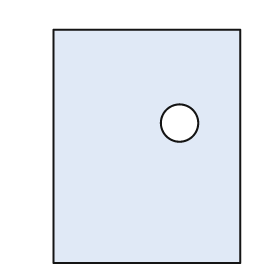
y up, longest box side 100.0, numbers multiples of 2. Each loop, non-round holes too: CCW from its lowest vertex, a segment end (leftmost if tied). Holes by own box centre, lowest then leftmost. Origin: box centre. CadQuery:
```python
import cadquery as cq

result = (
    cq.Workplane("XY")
    .moveTo(-40.0, -50.0)
    .lineTo(40.0, -50.0)
    .lineTo(40.0, 50.0)
    .lineTo(-40.0, 50.0)
    .close()
    .moveTo(14.0, 10.0)
    .circle(8.0)
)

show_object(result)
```